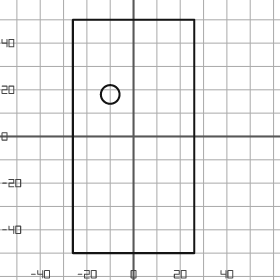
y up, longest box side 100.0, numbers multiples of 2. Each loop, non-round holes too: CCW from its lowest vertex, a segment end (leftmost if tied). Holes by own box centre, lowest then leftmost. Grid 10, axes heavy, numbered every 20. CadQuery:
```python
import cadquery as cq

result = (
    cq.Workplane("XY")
    .moveTo(-26.0, -50.0)
    .lineTo(26.0, -50.0)
    .lineTo(26.0, 50.0)
    .lineTo(-26.0, 50.0)
    .close()
    .moveTo(-10.0, 18.0)
    .circle(4.0)
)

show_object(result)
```